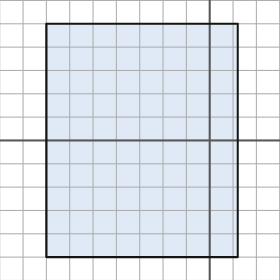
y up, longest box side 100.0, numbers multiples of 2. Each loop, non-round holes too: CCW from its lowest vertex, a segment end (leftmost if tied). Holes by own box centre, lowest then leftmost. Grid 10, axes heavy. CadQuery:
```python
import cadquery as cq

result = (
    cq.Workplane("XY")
    .moveTo(-70.0, -50.0)
    .lineTo(12.0, -50.0)
    .lineTo(12.0, 50.0)
    .lineTo(-70.0, 50.0)
    .close()
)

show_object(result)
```